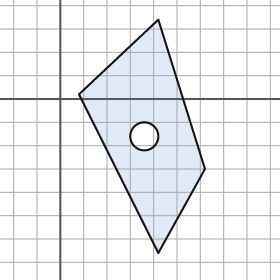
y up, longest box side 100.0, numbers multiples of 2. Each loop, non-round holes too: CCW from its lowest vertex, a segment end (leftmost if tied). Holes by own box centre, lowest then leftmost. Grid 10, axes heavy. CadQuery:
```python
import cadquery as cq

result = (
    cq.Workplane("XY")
    .moveTo(42.0, -66.0)
    .lineTo(62.0, -30.0)
    .lineTo(42.0, 34.0)
    .lineTo(8.0, 2.0)
    .close()
    .moveTo(36.0, -16.0)
    .circle(6.0)
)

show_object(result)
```